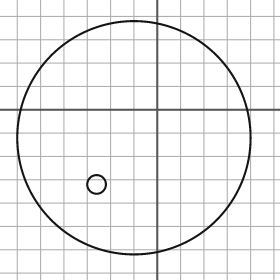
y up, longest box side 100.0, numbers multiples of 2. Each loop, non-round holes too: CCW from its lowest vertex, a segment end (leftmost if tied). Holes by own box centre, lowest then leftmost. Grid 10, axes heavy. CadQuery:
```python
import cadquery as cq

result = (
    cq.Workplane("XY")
    .moveTo(-10.0, -12.0)
    .circle(50.0)
    .moveTo(-26.0, -32.0)
    .circle(4.0)
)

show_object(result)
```